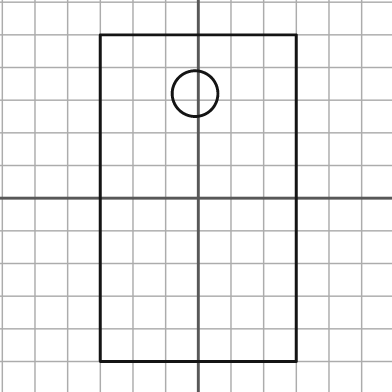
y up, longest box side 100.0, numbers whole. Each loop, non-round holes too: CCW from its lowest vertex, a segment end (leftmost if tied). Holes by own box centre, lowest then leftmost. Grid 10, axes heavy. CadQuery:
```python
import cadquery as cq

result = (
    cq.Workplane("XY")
    .moveTo(-30.0, -50.0)
    .lineTo(30.0, -50.0)
    .lineTo(30.0, 50.0)
    .lineTo(-30.0, 50.0)
    .close()
    .moveTo(-1.0, 32.0)
    .circle(7.0)
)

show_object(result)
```